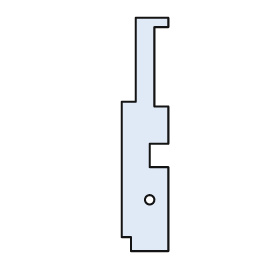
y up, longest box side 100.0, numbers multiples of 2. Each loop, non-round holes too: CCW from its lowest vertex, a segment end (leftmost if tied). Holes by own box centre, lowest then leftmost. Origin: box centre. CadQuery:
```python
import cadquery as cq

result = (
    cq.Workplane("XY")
    .moveTo(-6.0, -50.0)
    .lineTo(10.0, -50.0)
    .lineTo(10.0, -14.0)
    .lineTo(2.0, -14.0)
    .lineTo(2.0, -4.0)
    .lineTo(10.0, -4.0)
    .lineTo(10.0, 12.0)
    .lineTo(4.0, 12.0)
    .lineTo(4.0, 46.0)
    .lineTo(10.0, 46.0)
    .lineTo(10.0, 50.0)
    .lineTo(-4.0, 50.0)
    .lineTo(-4.0, 14.0)
    .lineTo(-10.0, 14.0)
    .lineTo(-10.0, -44.0)
    .lineTo(-6.0, -44.0)
    .close()
    .moveTo(2.0, -28.0)
    .circle(2.0)
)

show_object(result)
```